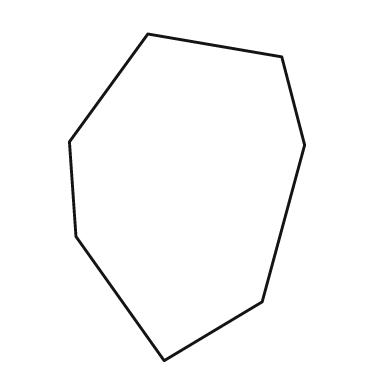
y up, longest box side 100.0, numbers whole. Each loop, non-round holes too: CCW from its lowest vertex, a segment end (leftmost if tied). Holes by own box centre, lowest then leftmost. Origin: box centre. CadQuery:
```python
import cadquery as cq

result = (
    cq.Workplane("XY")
    .moveTo(-7.0, -50.0)
    .lineTo(23.0, -32.0)
    .lineTo(36.0, 16.0)
    .lineTo(29.0, 43.0)
    .lineTo(-12.0, 50.0)
    .lineTo(-36.0, 17.0)
    .lineTo(-34.0, -12.0)
    .close()
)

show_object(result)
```